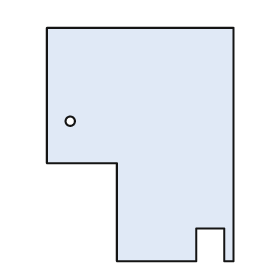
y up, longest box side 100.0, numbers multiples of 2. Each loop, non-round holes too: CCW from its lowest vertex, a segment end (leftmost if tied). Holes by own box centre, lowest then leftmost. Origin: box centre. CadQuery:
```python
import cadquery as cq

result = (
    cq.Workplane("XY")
    .moveTo(-10.0, -50.0)
    .lineTo(24.0, -50.0)
    .lineTo(24.0, -36.0)
    .lineTo(36.0, -36.0)
    .lineTo(36.0, -50.0)
    .lineTo(40.0, -50.0)
    .lineTo(40.0, 50.0)
    .lineTo(-40.0, 50.0)
    .lineTo(-40.0, -8.0)
    .lineTo(-10.0, -8.0)
    .close()
    .moveTo(-30.0, 10.0)
    .circle(2.0)
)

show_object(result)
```